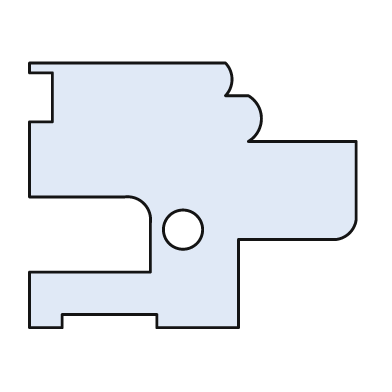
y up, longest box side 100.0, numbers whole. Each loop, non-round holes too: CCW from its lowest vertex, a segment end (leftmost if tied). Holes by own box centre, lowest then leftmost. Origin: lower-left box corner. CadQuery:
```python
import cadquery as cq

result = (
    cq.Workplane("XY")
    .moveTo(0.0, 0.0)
    .lineTo(10.0, 0.0)
    .lineTo(10.0, 4.0)
    .lineTo(39.0, 4.0)
    .lineTo(39.0, 0.0)
    .lineTo(64.0, 0.0)
    .lineTo(64.0, 27.0)
    .lineTo(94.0, 27.0)
    .threePointArc((98.0, 29.0), (100.0, 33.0))
    .lineTo(100.0, 57.0)
    .lineTo(67.0, 57.0)
    .threePointArc((71.0, 64.0), (67.0, 71.0))
    .lineTo(60.0, 71.0)
    .threePointArc((62.0, 76.0), (60.0, 81.0))
    .lineTo(0.0, 81.0)
    .lineTo(0.0, 78.0)
    .lineTo(7.0, 78.0)
    .lineTo(7.0, 63.0)
    .lineTo(0.0, 63.0)
    .lineTo(0.0, 40.0)
    .lineTo(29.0, 40.0)
    .threePointArc((35.0, 38.0), (37.0, 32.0))
    .lineTo(37.0, 17.0)
    .lineTo(0.0, 17.0)
    .close()
    .moveTo(47.0, 30.0)
    .circle(6.0)
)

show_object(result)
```